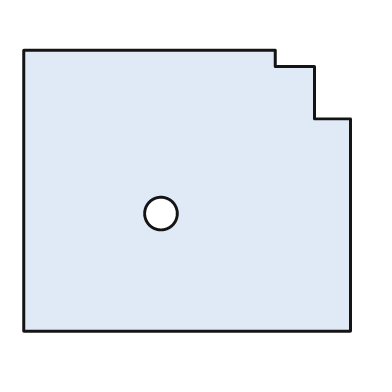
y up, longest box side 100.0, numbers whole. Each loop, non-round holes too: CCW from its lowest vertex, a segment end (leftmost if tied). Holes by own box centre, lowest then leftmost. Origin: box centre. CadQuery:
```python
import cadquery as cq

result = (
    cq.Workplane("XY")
    .moveTo(-50.0, -43.0)
    .lineTo(50.0, -43.0)
    .lineTo(50.0, 22.0)
    .lineTo(39.0, 22.0)
    .lineTo(39.0, 38.0)
    .lineTo(27.0, 38.0)
    .lineTo(27.0, 43.0)
    .lineTo(-50.0, 43.0)
    .close()
    .moveTo(-8.0, -7.0)
    .circle(5.0)
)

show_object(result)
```